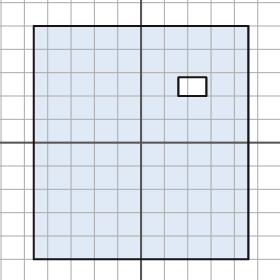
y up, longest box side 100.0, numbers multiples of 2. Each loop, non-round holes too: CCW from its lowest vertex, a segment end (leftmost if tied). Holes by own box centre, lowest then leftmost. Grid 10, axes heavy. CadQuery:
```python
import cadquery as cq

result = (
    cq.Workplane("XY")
    .moveTo(-46.0, -50.0)
    .lineTo(46.0, -50.0)
    .lineTo(46.0, 50.0)
    .lineTo(-46.0, 50.0)
    .close()
    .moveTo(16.0, 20.0)
    .lineTo(28.0, 20.0)
    .lineTo(28.0, 28.0)
    .lineTo(16.0, 28.0)
    .close()
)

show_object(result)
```